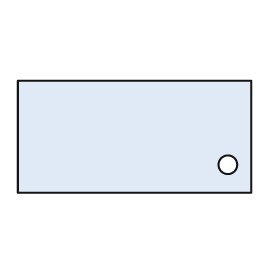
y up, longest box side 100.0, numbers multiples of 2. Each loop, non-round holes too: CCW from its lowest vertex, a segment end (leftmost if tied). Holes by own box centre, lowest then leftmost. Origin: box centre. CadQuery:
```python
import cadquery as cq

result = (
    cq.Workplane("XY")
    .moveTo(-50.0, -24.0)
    .lineTo(50.0, -24.0)
    .lineTo(50.0, 24.0)
    .lineTo(-50.0, 24.0)
    .close()
    .moveTo(40.0, -12.0)
    .circle(4.0)
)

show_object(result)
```